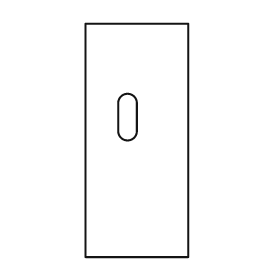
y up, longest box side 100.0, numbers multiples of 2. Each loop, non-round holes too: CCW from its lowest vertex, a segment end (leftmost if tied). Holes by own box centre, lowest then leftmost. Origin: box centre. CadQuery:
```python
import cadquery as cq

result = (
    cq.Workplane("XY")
    .moveTo(-22.0, -50.0)
    .lineTo(22.0, -50.0)
    .lineTo(22.0, 50.0)
    .lineTo(-22.0, 50.0)
    .close()
    .moveTo(-8.0, 4.0)
    .threePointArc((-4.0, 0.0), (0.0, 4.0))
    .lineTo(0.0, 16.0)
    .threePointArc((-4.0, 20.0), (-8.0, 16.0))
    .close()
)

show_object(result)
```